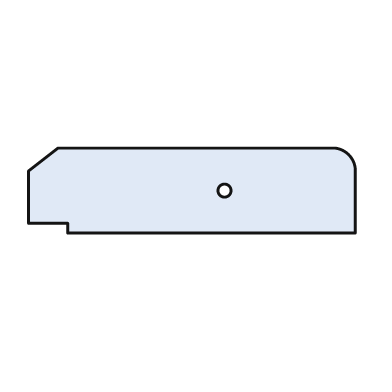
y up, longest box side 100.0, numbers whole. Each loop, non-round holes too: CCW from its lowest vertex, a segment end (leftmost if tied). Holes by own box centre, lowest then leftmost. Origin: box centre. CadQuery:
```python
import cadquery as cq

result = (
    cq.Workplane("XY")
    .moveTo(-38.0, -13.0)
    .lineTo(50.0, -13.0)
    .lineTo(50.0, 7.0)
    .threePointArc((48.0, 11.0), (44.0, 13.0))
    .lineTo(-41.0, 13.0)
    .lineTo(-50.0, 6.0)
    .lineTo(-50.0, -10.0)
    .lineTo(-38.0, -10.0)
    .close()
    .moveTo(10.0, 0.0)
    .circle(2.0)
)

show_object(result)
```